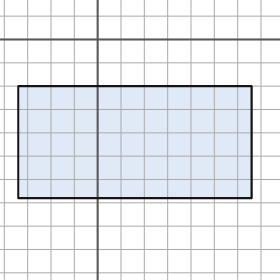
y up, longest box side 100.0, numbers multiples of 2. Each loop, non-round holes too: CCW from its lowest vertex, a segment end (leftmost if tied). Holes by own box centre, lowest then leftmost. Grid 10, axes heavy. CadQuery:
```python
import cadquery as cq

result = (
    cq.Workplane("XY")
    .moveTo(-34.0, -68.0)
    .lineTo(66.0, -68.0)
    .lineTo(66.0, -20.0)
    .lineTo(-34.0, -20.0)
    .close()
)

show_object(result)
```